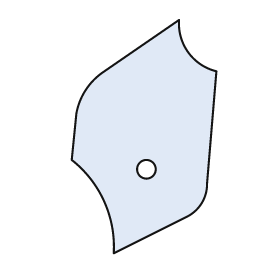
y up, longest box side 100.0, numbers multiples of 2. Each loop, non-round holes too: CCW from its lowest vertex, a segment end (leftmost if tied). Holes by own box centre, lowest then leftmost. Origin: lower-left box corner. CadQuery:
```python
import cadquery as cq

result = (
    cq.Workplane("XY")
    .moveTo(18.0, 0.0)
    .lineTo(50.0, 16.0)
    .threePointArc((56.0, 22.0), (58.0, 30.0))
    .lineTo(62.0, 78.0)
    .threePointArc((50.0, 86.0), (46.0, 100.0))
    .lineTo(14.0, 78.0)
    .threePointArc((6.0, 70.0), (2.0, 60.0))
    .lineTo(0.0, 40.0)
    .threePointArc((14.0, 22.0), (18.0, 0.0))
    .close()
    .moveTo(32.0, 36.0)
    .circle(4.0)
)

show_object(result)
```